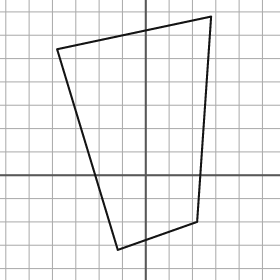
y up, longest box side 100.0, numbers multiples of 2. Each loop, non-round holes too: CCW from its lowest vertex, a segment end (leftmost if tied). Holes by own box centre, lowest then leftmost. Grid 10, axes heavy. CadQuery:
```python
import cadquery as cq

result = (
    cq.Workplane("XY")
    .moveTo(-12.0, -32.0)
    .lineTo(22.0, -20.0)
    .lineTo(28.0, 68.0)
    .lineTo(-38.0, 54.0)
    .close()
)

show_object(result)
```